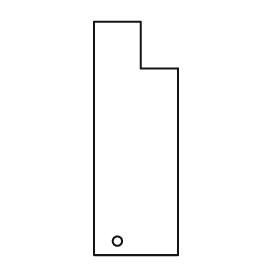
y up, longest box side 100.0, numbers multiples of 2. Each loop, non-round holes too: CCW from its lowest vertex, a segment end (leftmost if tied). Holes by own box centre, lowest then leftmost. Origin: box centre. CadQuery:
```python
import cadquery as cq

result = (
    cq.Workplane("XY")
    .moveTo(-18.0, -50.0)
    .lineTo(18.0, -50.0)
    .lineTo(18.0, 30.0)
    .lineTo(2.0, 30.0)
    .lineTo(2.0, 50.0)
    .lineTo(-18.0, 50.0)
    .close()
    .moveTo(-8.0, -44.0)
    .circle(2.0)
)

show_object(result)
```